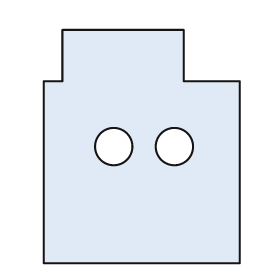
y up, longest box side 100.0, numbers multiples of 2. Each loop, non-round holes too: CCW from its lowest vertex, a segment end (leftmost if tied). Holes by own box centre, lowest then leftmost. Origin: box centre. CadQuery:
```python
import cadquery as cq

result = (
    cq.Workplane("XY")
    .moveTo(-42.0, -50.0)
    .lineTo(42.0, -50.0)
    .lineTo(42.0, 28.0)
    .lineTo(18.0, 28.0)
    .lineTo(18.0, 50.0)
    .lineTo(-34.0, 50.0)
    .lineTo(-34.0, 28.0)
    .lineTo(-42.0, 28.0)
    .close()
    .moveTo(-12.0, 0.0)
    .circle(8.0)
    .moveTo(14.0, 0.0)
    .circle(8.0)
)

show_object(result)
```